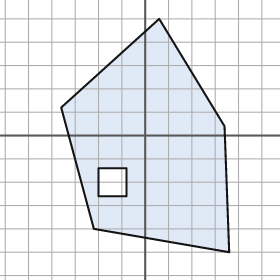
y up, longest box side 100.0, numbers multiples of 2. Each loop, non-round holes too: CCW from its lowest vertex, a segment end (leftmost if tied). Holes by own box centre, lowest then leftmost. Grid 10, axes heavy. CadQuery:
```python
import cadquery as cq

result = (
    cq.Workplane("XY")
    .moveTo(36.0, -50.0)
    .lineTo(34.0, 4.0)
    .lineTo(6.0, 50.0)
    .lineTo(-36.0, 12.0)
    .lineTo(-22.0, -40.0)
    .close()
    .moveTo(-20.0, -26.0)
    .lineTo(-8.0, -26.0)
    .lineTo(-8.0, -14.0)
    .lineTo(-20.0, -14.0)
    .close()
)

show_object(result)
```